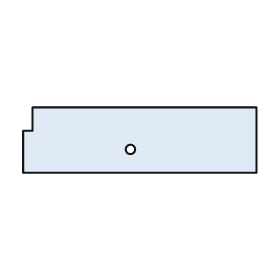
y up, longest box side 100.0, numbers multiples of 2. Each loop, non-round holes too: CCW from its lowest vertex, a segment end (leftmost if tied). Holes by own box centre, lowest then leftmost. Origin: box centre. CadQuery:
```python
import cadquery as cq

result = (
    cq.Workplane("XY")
    .moveTo(-50.0, -14.0)
    .lineTo(50.0, -14.0)
    .lineTo(50.0, 14.0)
    .lineTo(-46.0, 14.0)
    .lineTo(-46.0, 4.0)
    .lineTo(-50.0, 4.0)
    .close()
    .moveTo(-4.0, -4.0)
    .circle(2.0)
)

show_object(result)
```